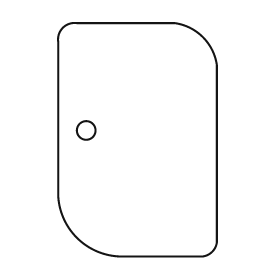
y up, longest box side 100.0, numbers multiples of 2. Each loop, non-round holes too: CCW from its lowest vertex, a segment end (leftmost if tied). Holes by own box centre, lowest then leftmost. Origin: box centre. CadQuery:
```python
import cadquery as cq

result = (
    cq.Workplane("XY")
    .moveTo(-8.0, -50.0)
    .lineTo(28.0, -50.0)
    .threePointArc((32.0, -48.0), (34.0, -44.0))
    .lineTo(34.0, 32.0)
    .threePointArc((28.0, 44.0), (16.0, 50.0))
    .lineTo(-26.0, 50.0)
    .threePointArc((-32.0, 48.0), (-34.0, 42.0))
    .lineTo(-34.0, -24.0)
    .threePointArc((-26.0, -42.0), (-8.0, -50.0))
    .close()
    .moveTo(-22.0, 4.0)
    .circle(4.0)
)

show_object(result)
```